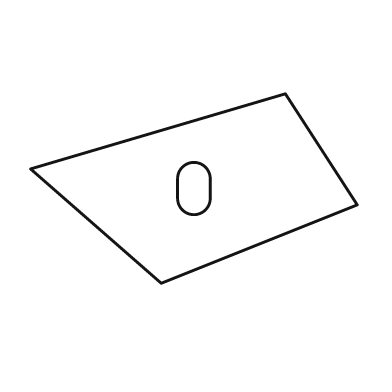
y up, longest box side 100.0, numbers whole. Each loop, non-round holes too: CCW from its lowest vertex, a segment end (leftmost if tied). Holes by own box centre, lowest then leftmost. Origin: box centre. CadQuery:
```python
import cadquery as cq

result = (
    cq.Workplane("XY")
    .moveTo(-10.0, -29.0)
    .lineTo(50.0, -5.0)
    .lineTo(28.0, 29.0)
    .lineTo(-50.0, 6.0)
    .close()
    .moveTo(-5.0, -3.0)
    .threePointArc((0.0, -8.0), (5.0, -3.0))
    .lineTo(5.0, 3.0)
    .threePointArc((0.0, 8.0), (-5.0, 3.0))
    .close()
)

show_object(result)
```